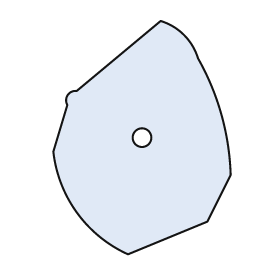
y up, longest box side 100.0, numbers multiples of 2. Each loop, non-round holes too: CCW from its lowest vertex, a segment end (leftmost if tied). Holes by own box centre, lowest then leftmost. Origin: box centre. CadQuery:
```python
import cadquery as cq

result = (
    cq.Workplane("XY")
    .moveTo(-6.0, -50.0)
    .lineTo(28.0, -36.0)
    .lineTo(38.0, -16.0)
    .threePointArc((34.0, 10.0), (24.0, 34.0))
    .threePointArc((18.0, 44.0), (8.0, 50.0))
    .lineTo(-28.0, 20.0)
    .threePointArc((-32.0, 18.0), (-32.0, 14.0))
    .lineTo(-38.0, -6.0)
    .threePointArc((-28.0, -32.0), (-6.0, -50.0))
    .close()
    .moveTo(0.0, 0.0)
    .circle(4.0)
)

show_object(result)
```